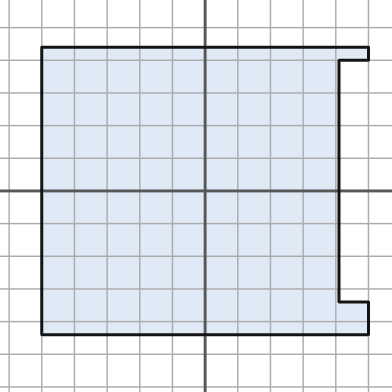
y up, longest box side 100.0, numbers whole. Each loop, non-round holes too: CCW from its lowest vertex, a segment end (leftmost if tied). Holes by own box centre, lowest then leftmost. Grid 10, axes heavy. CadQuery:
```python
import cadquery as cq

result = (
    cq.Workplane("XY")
    .moveTo(-50.0, -44.0)
    .lineTo(50.0, -44.0)
    .lineTo(50.0, -34.0)
    .lineTo(41.0, -34.0)
    .lineTo(41.0, 40.0)
    .lineTo(50.0, 40.0)
    .lineTo(50.0, 44.0)
    .lineTo(-50.0, 44.0)
    .close()
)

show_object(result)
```